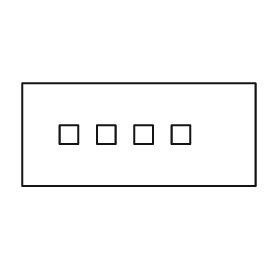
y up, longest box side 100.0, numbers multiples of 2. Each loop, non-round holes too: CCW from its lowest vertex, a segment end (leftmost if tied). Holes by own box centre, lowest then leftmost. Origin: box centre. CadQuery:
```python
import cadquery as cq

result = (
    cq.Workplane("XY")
    .moveTo(-50.0, -22.0)
    .lineTo(50.0, -22.0)
    .lineTo(50.0, 22.0)
    .lineTo(-50.0, 22.0)
    .close()
    .moveTo(-34.0, -4.0)
    .lineTo(-26.0, -4.0)
    .lineTo(-26.0, 4.0)
    .lineTo(-34.0, 4.0)
    .close()
    .moveTo(-18.0, -4.0)
    .lineTo(-10.0, -4.0)
    .lineTo(-10.0, 4.0)
    .lineTo(-18.0, 4.0)
    .close()
    .moveTo(-2.0, -4.0)
    .lineTo(6.0, -4.0)
    .lineTo(6.0, 4.0)
    .lineTo(-2.0, 4.0)
    .close()
    .moveTo(14.0, -4.0)
    .lineTo(22.0, -4.0)
    .lineTo(22.0, 4.0)
    .lineTo(14.0, 4.0)
    .close()
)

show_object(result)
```